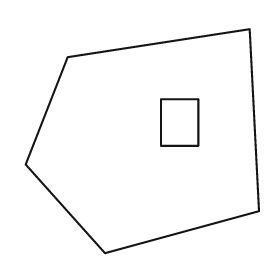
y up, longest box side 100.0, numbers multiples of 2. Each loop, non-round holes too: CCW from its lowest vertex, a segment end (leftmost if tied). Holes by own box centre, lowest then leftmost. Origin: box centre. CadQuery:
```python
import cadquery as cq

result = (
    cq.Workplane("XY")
    .moveTo(-16.0, -48.0)
    .lineTo(50.0, -30.0)
    .lineTo(46.0, 48.0)
    .lineTo(-32.0, 36.0)
    .lineTo(-50.0, -10.0)
    .close()
    .moveTo(8.0, -2.0)
    .lineTo(24.0, -2.0)
    .lineTo(24.0, 18.0)
    .lineTo(8.0, 18.0)
    .close()
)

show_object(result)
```